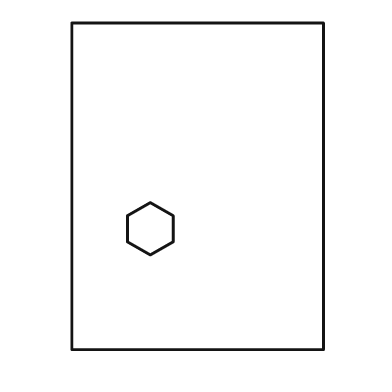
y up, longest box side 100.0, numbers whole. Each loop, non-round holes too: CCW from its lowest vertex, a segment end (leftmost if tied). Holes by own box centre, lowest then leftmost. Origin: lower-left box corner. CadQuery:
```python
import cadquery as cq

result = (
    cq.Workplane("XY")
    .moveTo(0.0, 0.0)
    .lineTo(77.0, 0.0)
    .lineTo(77.0, 100.0)
    .lineTo(0.0, 100.0)
    .close()
    .moveTo(24.0, 29.0)
    .lineTo(31.0, 33.0)
    .lineTo(31.0, 41.0)
    .lineTo(24.0, 45.0)
    .lineTo(17.0, 41.0)
    .lineTo(17.0, 33.0)
    .close()
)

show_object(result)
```